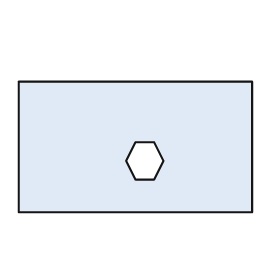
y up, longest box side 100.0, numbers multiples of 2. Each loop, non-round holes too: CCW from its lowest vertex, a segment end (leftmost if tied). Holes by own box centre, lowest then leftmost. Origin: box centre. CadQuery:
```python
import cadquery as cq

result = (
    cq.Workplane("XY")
    .moveTo(-50.0, -28.0)
    .lineTo(50.0, -28.0)
    .lineTo(50.0, 28.0)
    .lineTo(-50.0, 28.0)
    .close()
    .moveTo(0.0, -14.0)
    .lineTo(8.0, -14.0)
    .lineTo(12.0, -6.0)
    .lineTo(8.0, 2.0)
    .lineTo(0.0, 2.0)
    .lineTo(-4.0, -6.0)
    .close()
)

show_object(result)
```